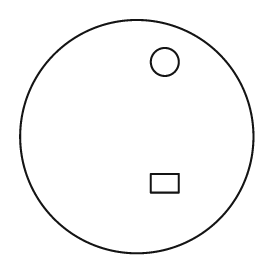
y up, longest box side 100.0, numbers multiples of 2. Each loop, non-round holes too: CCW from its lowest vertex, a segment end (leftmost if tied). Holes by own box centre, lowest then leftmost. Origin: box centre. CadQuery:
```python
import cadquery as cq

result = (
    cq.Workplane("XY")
    .moveTo(0.0, 0.0)
    .circle(50.0)
    .moveTo(6.0, -24.0)
    .lineTo(18.0, -24.0)
    .lineTo(18.0, -16.0)
    .lineTo(6.0, -16.0)
    .close()
    .moveTo(12.0, 32.0)
    .circle(6.0)
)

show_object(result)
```